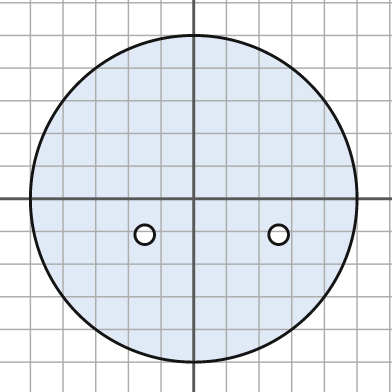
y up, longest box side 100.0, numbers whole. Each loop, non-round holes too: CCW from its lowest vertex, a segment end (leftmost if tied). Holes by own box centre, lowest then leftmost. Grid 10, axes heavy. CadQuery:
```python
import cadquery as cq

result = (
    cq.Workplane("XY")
    .moveTo(0.0, 0.0)
    .circle(50.0)
    .moveTo(-15.0, -11.0)
    .circle(3.0)
    .moveTo(26.0, -11.0)
    .circle(3.0)
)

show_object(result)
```